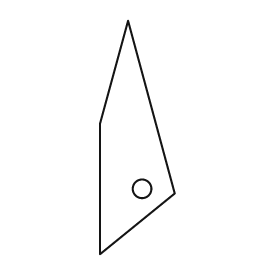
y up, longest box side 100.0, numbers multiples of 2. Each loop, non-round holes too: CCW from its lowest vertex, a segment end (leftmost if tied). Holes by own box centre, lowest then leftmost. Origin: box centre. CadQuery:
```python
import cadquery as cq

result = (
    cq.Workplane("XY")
    .moveTo(-16.0, -50.0)
    .lineTo(16.0, -24.0)
    .lineTo(-4.0, 50.0)
    .lineTo(-16.0, 6.0)
    .close()
    .moveTo(2.0, -22.0)
    .circle(4.0)
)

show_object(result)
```